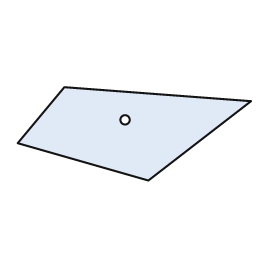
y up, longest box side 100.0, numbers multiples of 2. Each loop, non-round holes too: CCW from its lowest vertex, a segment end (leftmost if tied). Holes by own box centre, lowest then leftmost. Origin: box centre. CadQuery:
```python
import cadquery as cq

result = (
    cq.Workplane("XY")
    .moveTo(6.0, -20.0)
    .lineTo(50.0, 14.0)
    .lineTo(-30.0, 20.0)
    .lineTo(-50.0, -4.0)
    .close()
    .moveTo(-4.0, 6.0)
    .circle(2.0)
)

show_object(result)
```